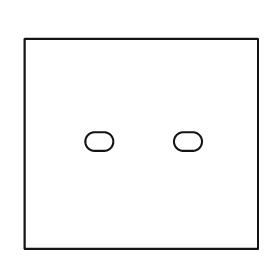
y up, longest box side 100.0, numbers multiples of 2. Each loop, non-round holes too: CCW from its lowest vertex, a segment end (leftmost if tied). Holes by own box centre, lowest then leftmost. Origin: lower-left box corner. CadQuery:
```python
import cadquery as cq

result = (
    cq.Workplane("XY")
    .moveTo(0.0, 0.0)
    .lineTo(100.0, 0.0)
    .lineTo(100.0, 90.0)
    .lineTo(0.0, 90.0)
    .close()
    .moveTo(30.0, 42.0)
    .lineTo(34.0, 42.0)
    .threePointArc((38.0, 46.0), (34.0, 50.0))
    .lineTo(30.0, 50.0)
    .threePointArc((26.0, 46.0), (30.0, 42.0))
    .close()
    .moveTo(68.0, 42.0)
    .lineTo(72.0, 42.0)
    .threePointArc((76.0, 46.0), (72.0, 50.0))
    .lineTo(68.0, 50.0)
    .threePointArc((64.0, 46.0), (68.0, 42.0))
    .close()
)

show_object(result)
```